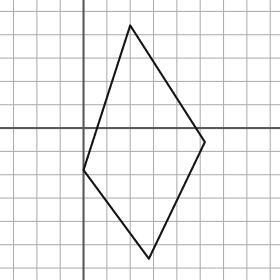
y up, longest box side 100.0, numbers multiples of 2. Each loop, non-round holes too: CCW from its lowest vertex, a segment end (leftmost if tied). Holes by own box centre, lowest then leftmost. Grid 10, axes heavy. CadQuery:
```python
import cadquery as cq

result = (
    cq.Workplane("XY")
    .moveTo(28.0, -56.0)
    .lineTo(52.0, -6.0)
    .lineTo(20.0, 44.0)
    .lineTo(0.0, -18.0)
    .close()
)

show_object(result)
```